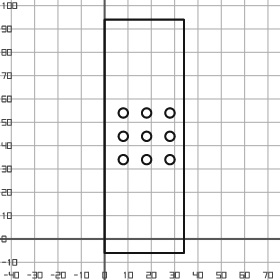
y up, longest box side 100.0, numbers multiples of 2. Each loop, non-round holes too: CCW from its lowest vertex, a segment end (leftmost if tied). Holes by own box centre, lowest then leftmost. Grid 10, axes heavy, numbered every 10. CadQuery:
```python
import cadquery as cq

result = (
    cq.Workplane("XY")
    .moveTo(0.0, -6.0)
    .lineTo(34.0, -6.0)
    .lineTo(34.0, 94.0)
    .lineTo(0.0, 94.0)
    .close()
    .moveTo(8.0, 34.0)
    .circle(2.0)
    .moveTo(18.0, 34.0)
    .circle(2.0)
    .moveTo(28.0, 34.0)
    .circle(2.0)
    .moveTo(8.0, 44.0)
    .circle(2.0)
    .moveTo(18.0, 44.0)
    .circle(2.0)
    .moveTo(28.0, 44.0)
    .circle(2.0)
    .moveTo(8.0, 54.0)
    .circle(2.0)
    .moveTo(18.0, 54.0)
    .circle(2.0)
    .moveTo(28.0, 54.0)
    .circle(2.0)
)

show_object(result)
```